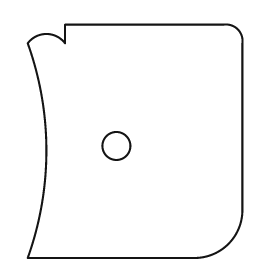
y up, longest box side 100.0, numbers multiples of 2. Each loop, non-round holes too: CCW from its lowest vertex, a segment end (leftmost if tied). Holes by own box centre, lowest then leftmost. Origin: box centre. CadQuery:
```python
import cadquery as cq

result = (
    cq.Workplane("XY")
    .moveTo(-46.0, -50.0)
    .lineTo(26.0, -50.0)
    .threePointArc((40.0, -44.0), (46.0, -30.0))
    .lineTo(46.0, 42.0)
    .threePointArc((44.0, 48.0), (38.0, 50.0))
    .lineTo(-30.0, 50.0)
    .lineTo(-30.0, 42.0)
    .threePointArc((-38.0, 46.0), (-46.0, 42.0))
    .threePointArc((-38.0, -4.0), (-46.0, -50.0))
    .close()
    .moveTo(-8.0, -2.0)
    .circle(6.0)
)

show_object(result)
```